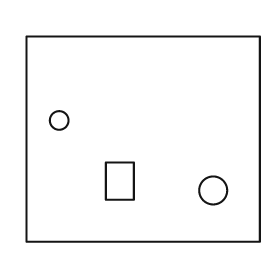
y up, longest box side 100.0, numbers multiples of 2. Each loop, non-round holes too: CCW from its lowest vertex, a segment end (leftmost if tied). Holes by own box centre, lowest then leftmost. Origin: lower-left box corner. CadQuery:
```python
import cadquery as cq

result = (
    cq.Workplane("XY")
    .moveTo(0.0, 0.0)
    .lineTo(100.0, 0.0)
    .lineTo(100.0, 88.0)
    .lineTo(0.0, 88.0)
    .close()
    .moveTo(80.0, 22.0)
    .circle(6.0)
    .moveTo(34.0, 18.0)
    .lineTo(46.0, 18.0)
    .lineTo(46.0, 34.0)
    .lineTo(34.0, 34.0)
    .close()
    .moveTo(14.0, 52.0)
    .circle(4.0)
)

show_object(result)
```